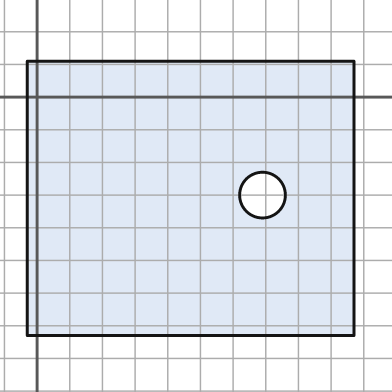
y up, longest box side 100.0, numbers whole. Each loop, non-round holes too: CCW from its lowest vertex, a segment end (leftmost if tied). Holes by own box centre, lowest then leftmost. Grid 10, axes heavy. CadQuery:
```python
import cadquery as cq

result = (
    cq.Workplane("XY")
    .moveTo(-3.0, -73.0)
    .lineTo(97.0, -73.0)
    .lineTo(97.0, 11.0)
    .lineTo(-3.0, 11.0)
    .close()
    .moveTo(69.0, -30.0)
    .circle(7.0)
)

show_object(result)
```